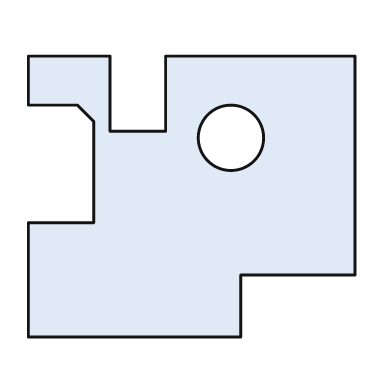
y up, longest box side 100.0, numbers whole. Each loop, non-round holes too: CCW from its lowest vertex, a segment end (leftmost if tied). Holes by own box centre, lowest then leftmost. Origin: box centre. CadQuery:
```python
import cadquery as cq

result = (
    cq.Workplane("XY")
    .moveTo(-50.0, -43.0)
    .lineTo(15.0, -43.0)
    .lineTo(15.0, -24.0)
    .lineTo(50.0, -24.0)
    .lineTo(50.0, 43.0)
    .lineTo(-8.0, 43.0)
    .lineTo(-8.0, 20.0)
    .lineTo(-25.0, 20.0)
    .lineTo(-25.0, 43.0)
    .lineTo(-50.0, 43.0)
    .lineTo(-50.0, 28.0)
    .lineTo(-35.0, 28.0)
    .lineTo(-30.0, 23.0)
    .lineTo(-30.0, -8.0)
    .lineTo(-50.0, -8.0)
    .close()
    .moveTo(12.0, 18.0)
    .circle(10.0)
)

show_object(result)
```